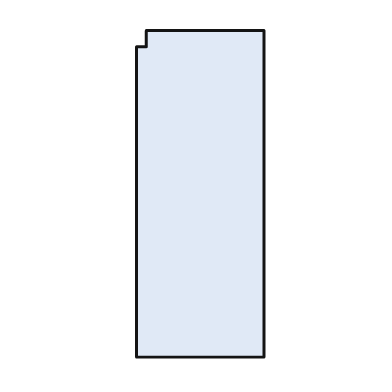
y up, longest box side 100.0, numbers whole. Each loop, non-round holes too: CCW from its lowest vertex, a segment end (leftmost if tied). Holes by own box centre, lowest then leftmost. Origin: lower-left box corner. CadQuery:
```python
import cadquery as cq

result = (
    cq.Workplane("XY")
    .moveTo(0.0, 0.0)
    .lineTo(39.0, 0.0)
    .lineTo(39.0, 100.0)
    .lineTo(3.0, 100.0)
    .lineTo(3.0, 95.0)
    .lineTo(0.0, 95.0)
    .close()
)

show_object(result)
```